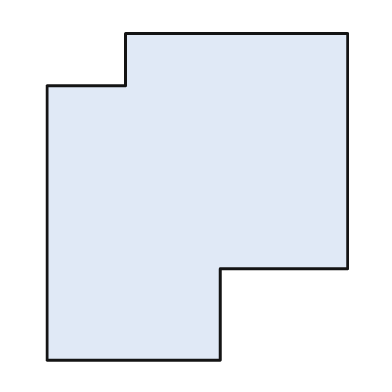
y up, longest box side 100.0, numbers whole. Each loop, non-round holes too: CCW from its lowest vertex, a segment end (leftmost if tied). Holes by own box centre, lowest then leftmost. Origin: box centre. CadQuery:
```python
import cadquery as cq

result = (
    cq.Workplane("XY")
    .moveTo(-46.0, -50.0)
    .lineTo(7.0, -50.0)
    .lineTo(7.0, -22.0)
    .lineTo(46.0, -22.0)
    .lineTo(46.0, 50.0)
    .lineTo(-22.0, 50.0)
    .lineTo(-22.0, 34.0)
    .lineTo(-46.0, 34.0)
    .close()
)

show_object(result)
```